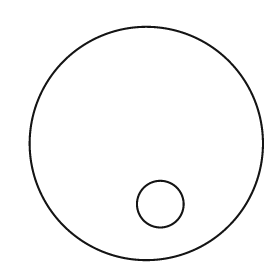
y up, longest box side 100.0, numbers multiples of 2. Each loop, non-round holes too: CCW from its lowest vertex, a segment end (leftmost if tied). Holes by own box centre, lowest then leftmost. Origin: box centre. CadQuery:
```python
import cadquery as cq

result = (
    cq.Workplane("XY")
    .moveTo(0.0, 0.0)
    .circle(50.0)
    .moveTo(6.0, -26.0)
    .circle(10.0)
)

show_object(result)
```